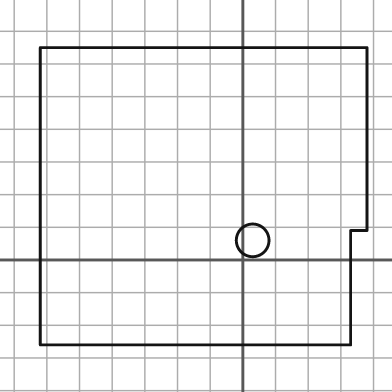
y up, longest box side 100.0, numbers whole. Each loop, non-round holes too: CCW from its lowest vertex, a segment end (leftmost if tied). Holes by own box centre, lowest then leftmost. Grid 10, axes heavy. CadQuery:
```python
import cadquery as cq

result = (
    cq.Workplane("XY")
    .moveTo(-62.0, -26.0)
    .lineTo(33.0, -26.0)
    .lineTo(33.0, 9.0)
    .lineTo(38.0, 9.0)
    .lineTo(38.0, 65.0)
    .lineTo(-62.0, 65.0)
    .close()
    .moveTo(3.0, 6.0)
    .circle(5.0)
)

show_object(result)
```